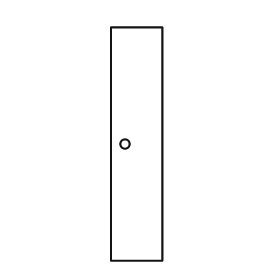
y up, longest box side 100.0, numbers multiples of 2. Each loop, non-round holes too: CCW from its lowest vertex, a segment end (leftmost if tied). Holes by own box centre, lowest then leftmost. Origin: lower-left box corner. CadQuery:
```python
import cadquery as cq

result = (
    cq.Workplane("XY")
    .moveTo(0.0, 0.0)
    .lineTo(22.0, 0.0)
    .lineTo(22.0, 100.0)
    .lineTo(0.0, 100.0)
    .close()
    .moveTo(6.0, 50.0)
    .circle(2.0)
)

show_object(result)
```